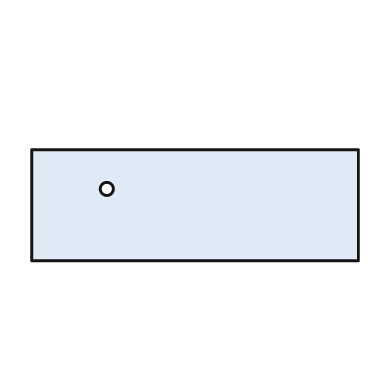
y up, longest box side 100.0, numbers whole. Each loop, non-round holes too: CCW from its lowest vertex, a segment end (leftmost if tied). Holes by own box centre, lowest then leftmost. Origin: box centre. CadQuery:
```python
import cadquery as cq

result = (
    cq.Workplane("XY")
    .moveTo(-50.0, -17.0)
    .lineTo(50.0, -17.0)
    .lineTo(50.0, 17.0)
    .lineTo(-50.0, 17.0)
    .close()
    .moveTo(-27.0, 5.0)
    .circle(2.0)
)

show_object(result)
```